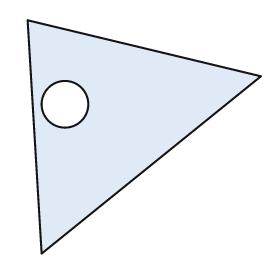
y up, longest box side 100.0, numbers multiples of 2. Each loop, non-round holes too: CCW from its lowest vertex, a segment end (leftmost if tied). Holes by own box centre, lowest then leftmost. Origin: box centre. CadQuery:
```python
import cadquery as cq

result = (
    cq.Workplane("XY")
    .moveTo(-44.0, -50.0)
    .lineTo(50.0, 26.0)
    .lineTo(-50.0, 50.0)
    .close()
    .moveTo(-34.0, 14.0)
    .circle(10.0)
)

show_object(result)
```